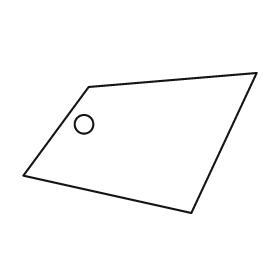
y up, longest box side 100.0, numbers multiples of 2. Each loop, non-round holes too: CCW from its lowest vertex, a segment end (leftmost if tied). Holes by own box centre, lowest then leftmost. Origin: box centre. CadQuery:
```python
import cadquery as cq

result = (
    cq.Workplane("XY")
    .moveTo(22.0, -30.0)
    .lineTo(50.0, 30.0)
    .lineTo(-22.0, 24.0)
    .lineTo(-50.0, -14.0)
    .close()
    .moveTo(-24.0, 8.0)
    .circle(4.0)
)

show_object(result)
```